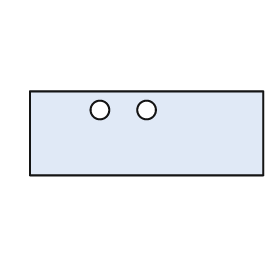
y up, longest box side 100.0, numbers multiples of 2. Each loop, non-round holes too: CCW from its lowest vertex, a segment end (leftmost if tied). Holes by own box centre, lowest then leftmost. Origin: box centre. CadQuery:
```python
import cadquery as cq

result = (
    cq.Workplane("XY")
    .moveTo(-50.0, -18.0)
    .lineTo(50.0, -18.0)
    .lineTo(50.0, 18.0)
    .lineTo(-50.0, 18.0)
    .close()
    .moveTo(-20.0, 10.0)
    .circle(4.0)
    .moveTo(0.0, 10.0)
    .circle(4.0)
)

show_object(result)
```